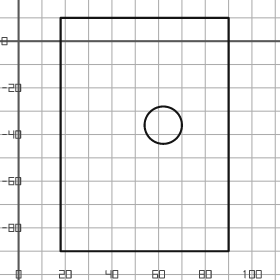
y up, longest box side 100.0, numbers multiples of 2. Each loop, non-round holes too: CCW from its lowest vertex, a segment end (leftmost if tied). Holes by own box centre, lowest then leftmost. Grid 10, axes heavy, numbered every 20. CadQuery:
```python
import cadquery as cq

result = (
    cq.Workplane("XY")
    .moveTo(18.0, -90.0)
    .lineTo(90.0, -90.0)
    .lineTo(90.0, 10.0)
    .lineTo(18.0, 10.0)
    .close()
    .moveTo(62.0, -36.0)
    .circle(8.0)
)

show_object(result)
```